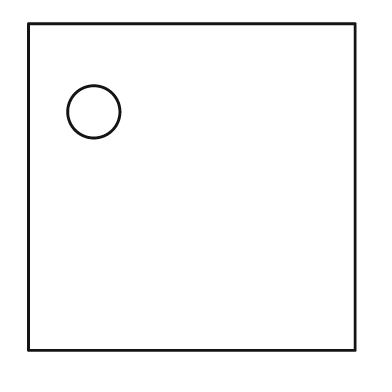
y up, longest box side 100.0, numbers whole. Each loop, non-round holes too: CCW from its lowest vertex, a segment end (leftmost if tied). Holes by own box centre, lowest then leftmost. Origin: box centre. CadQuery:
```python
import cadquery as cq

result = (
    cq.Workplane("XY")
    .moveTo(-50.0, -50.0)
    .lineTo(50.0, -50.0)
    .lineTo(50.0, 50.0)
    .lineTo(-50.0, 50.0)
    .close()
    .moveTo(-30.0, 23.0)
    .circle(8.0)
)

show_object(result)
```